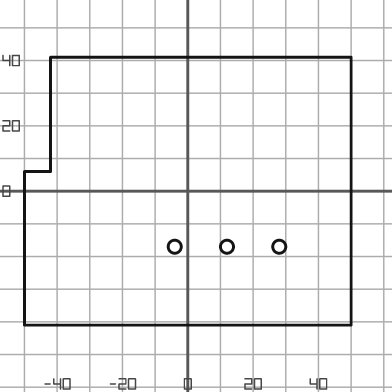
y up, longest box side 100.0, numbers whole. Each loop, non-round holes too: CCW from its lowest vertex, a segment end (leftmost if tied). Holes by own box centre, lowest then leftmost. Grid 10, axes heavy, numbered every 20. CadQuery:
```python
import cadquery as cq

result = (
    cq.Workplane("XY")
    .moveTo(-50.0, -41.0)
    .lineTo(50.0, -41.0)
    .lineTo(50.0, 41.0)
    .lineTo(-42.0, 41.0)
    .lineTo(-42.0, 6.0)
    .lineTo(-50.0, 6.0)
    .close()
    .moveTo(-4.0, -17.0)
    .circle(2.0)
    .moveTo(12.0, -17.0)
    .circle(2.0)
    .moveTo(28.0, -17.0)
    .circle(2.0)
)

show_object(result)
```